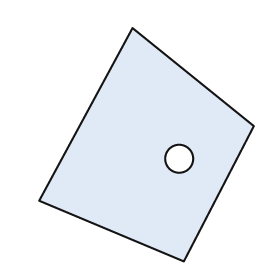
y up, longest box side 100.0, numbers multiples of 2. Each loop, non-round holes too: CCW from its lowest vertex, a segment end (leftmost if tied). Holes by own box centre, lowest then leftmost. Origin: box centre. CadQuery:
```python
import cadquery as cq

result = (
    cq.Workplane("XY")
    .moveTo(16.0, -50.0)
    .lineTo(46.0, 8.0)
    .lineTo(-6.0, 50.0)
    .lineTo(-46.0, -24.0)
    .close()
    .moveTo(14.0, -6.0)
    .circle(6.0)
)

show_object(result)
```